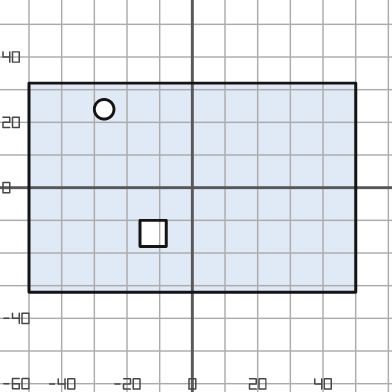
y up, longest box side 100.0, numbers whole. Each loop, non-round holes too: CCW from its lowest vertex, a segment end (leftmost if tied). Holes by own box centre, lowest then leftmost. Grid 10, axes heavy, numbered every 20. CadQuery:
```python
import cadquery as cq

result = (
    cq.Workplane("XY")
    .moveTo(-50.0, -32.0)
    .lineTo(50.0, -32.0)
    .lineTo(50.0, 32.0)
    .lineTo(-50.0, 32.0)
    .close()
    .moveTo(-16.0, -18.0)
    .lineTo(-8.0, -18.0)
    .lineTo(-8.0, -10.0)
    .lineTo(-16.0, -10.0)
    .close()
    .moveTo(-27.0, 24.0)
    .circle(3.0)
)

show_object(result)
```